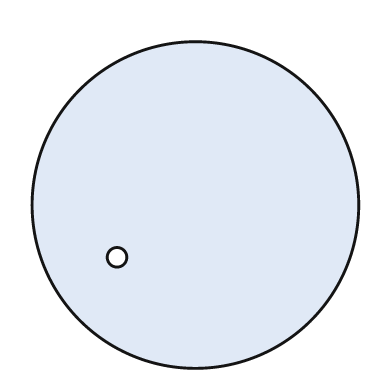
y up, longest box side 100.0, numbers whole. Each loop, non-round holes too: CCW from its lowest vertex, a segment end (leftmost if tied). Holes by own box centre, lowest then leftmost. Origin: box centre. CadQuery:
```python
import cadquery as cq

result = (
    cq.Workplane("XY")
    .moveTo(0.0, 0.0)
    .circle(50.0)
    .moveTo(-24.0, -16.0)
    .circle(3.0)
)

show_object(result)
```